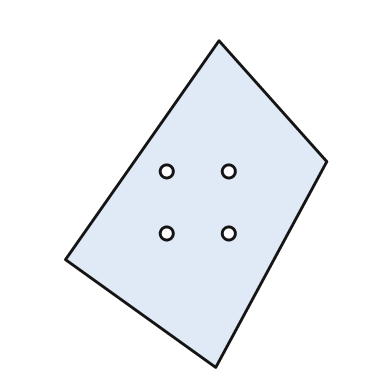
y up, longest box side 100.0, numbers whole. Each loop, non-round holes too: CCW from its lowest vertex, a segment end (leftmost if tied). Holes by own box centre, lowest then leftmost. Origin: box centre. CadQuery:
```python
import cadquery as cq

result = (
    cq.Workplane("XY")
    .moveTo(6.0, -50.0)
    .lineTo(40.0, 13.0)
    .lineTo(7.0, 50.0)
    .lineTo(-40.0, -17.0)
    .close()
    .moveTo(-9.0, -9.0)
    .circle(2.0)
    .moveTo(10.0, -9.0)
    .circle(2.0)
    .moveTo(-9.0, 10.0)
    .circle(2.0)
    .moveTo(10.0, 10.0)
    .circle(2.0)
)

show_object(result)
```